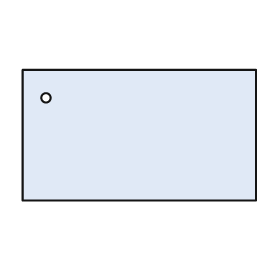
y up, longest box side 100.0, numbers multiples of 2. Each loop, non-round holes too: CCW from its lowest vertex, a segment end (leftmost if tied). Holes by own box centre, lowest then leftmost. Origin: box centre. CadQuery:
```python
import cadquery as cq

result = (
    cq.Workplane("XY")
    .moveTo(-50.0, -28.0)
    .lineTo(50.0, -28.0)
    .lineTo(50.0, 28.0)
    .lineTo(-50.0, 28.0)
    .close()
    .moveTo(-40.0, 16.0)
    .circle(2.0)
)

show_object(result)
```